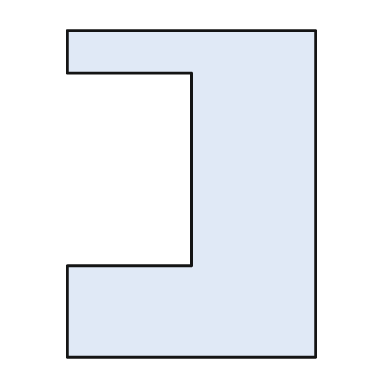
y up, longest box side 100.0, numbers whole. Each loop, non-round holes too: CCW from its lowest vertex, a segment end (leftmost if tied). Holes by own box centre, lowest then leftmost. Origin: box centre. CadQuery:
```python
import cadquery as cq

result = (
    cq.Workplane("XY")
    .moveTo(-38.0, -50.0)
    .lineTo(38.0, -50.0)
    .lineTo(38.0, 50.0)
    .lineTo(-38.0, 50.0)
    .lineTo(-38.0, 37.0)
    .lineTo(0.0, 37.0)
    .lineTo(0.0, -22.0)
    .lineTo(-38.0, -22.0)
    .close()
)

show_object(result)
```